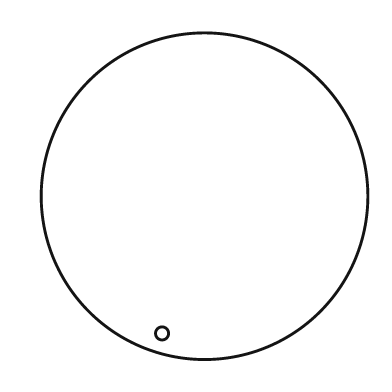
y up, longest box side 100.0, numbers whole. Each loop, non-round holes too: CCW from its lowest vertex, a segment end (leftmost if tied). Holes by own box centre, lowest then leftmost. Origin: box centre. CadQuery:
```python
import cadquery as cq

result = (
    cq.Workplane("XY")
    .moveTo(0.0, 0.0)
    .circle(50.0)
    .moveTo(-13.0, -42.0)
    .circle(2.0)
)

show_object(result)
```